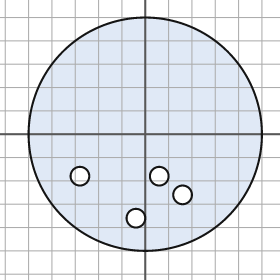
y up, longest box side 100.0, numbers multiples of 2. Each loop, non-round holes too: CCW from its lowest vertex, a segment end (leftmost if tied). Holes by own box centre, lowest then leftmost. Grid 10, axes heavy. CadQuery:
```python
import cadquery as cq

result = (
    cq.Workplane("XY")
    .moveTo(0.0, 0.0)
    .circle(50.0)
    .moveTo(-4.0, -36.0)
    .circle(4.0)
    .moveTo(16.0, -26.0)
    .circle(4.0)
    .moveTo(-28.0, -18.0)
    .circle(4.0)
    .moveTo(6.0, -18.0)
    .circle(4.0)
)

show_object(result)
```